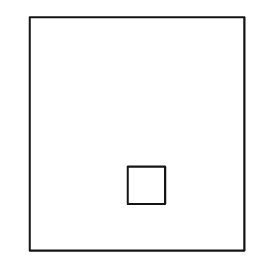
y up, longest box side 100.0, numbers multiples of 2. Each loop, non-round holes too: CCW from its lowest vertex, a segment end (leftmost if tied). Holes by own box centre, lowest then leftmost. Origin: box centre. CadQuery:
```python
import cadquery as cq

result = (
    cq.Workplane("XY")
    .moveTo(-46.0, -50.0)
    .lineTo(46.0, -50.0)
    .lineTo(46.0, 50.0)
    .lineTo(-46.0, 50.0)
    .close()
    .moveTo(-4.0, -30.0)
    .lineTo(12.0, -30.0)
    .lineTo(12.0, -14.0)
    .lineTo(-4.0, -14.0)
    .close()
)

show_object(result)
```